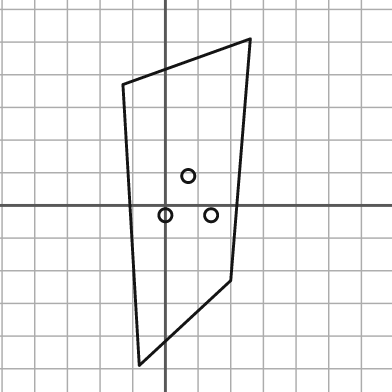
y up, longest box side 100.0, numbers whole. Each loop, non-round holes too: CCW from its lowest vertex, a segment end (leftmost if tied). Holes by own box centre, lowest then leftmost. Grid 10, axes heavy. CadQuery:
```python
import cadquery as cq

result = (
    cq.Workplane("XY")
    .moveTo(-8.0, -49.0)
    .lineTo(20.0, -23.0)
    .lineTo(26.0, 51.0)
    .lineTo(-13.0, 37.0)
    .close()
    .moveTo(0.0, -3.0)
    .circle(2.0)
    .moveTo(14.0, -3.0)
    .circle(2.0)
    .moveTo(7.0, 9.0)
    .circle(2.0)
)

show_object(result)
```